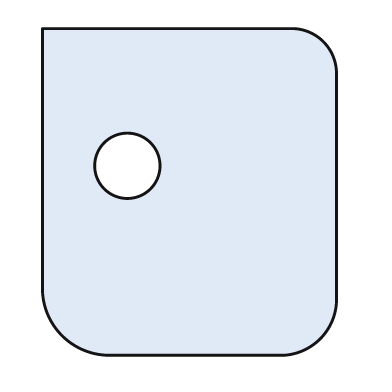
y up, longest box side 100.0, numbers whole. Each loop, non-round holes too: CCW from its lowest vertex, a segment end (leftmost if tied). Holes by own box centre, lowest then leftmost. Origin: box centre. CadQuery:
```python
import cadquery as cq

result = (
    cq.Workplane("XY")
    .moveTo(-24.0, -50.0)
    .lineTo(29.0, -50.0)
    .threePointArc((40.0, -45.0), (45.0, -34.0))
    .lineTo(45.0, 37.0)
    .threePointArc((41.0, 46.0), (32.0, 50.0))
    .lineTo(-45.0, 50.0)
    .lineTo(-45.0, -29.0)
    .threePointArc((-39.0, -44.0), (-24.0, -50.0))
    .close()
    .moveTo(-19.0, 8.0)
    .circle(10.0)
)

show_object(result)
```